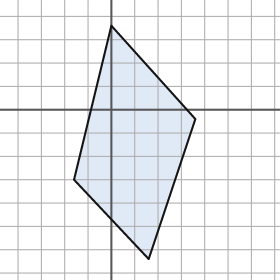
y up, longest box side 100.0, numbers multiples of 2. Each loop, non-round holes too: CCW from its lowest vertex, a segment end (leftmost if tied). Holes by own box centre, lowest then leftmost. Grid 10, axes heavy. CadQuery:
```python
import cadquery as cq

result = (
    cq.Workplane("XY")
    .moveTo(16.0, -64.0)
    .lineTo(36.0, -4.0)
    .lineTo(0.0, 36.0)
    .lineTo(-16.0, -30.0)
    .close()
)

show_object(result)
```